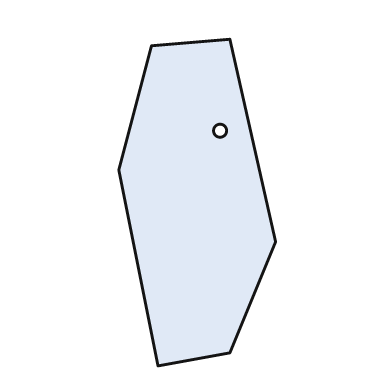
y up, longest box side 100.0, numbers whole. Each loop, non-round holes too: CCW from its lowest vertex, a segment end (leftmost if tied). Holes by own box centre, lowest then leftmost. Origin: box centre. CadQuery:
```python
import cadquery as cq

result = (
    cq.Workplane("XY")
    .moveTo(-12.0, -50.0)
    .lineTo(10.0, -46.0)
    .lineTo(24.0, -12.0)
    .lineTo(10.0, 50.0)
    .lineTo(-14.0, 48.0)
    .lineTo(-24.0, 10.0)
    .close()
    .moveTo(7.0, 22.0)
    .circle(2.0)
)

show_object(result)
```